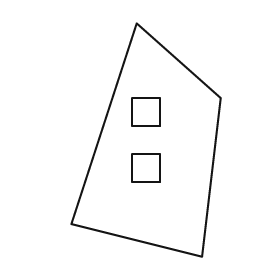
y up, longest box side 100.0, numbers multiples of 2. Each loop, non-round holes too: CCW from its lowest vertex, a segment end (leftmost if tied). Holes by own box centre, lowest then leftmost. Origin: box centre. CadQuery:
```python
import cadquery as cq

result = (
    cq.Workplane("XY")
    .moveTo(24.0, -50.0)
    .lineTo(32.0, 18.0)
    .lineTo(-4.0, 50.0)
    .lineTo(-32.0, -36.0)
    .close()
    .moveTo(-6.0, -18.0)
    .lineTo(6.0, -18.0)
    .lineTo(6.0, -6.0)
    .lineTo(-6.0, -6.0)
    .close()
    .moveTo(-6.0, 6.0)
    .lineTo(6.0, 6.0)
    .lineTo(6.0, 18.0)
    .lineTo(-6.0, 18.0)
    .close()
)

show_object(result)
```